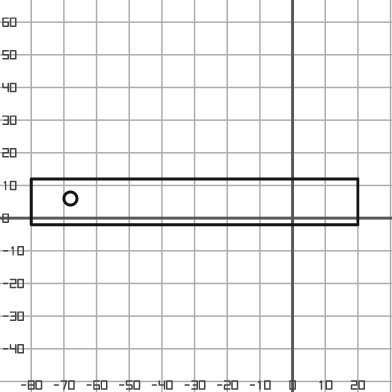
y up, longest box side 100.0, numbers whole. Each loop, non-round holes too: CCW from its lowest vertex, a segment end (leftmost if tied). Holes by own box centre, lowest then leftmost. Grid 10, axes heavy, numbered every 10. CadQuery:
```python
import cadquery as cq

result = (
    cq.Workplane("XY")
    .moveTo(-80.0, -2.0)
    .lineTo(20.0, -2.0)
    .lineTo(20.0, 12.0)
    .lineTo(-80.0, 12.0)
    .close()
    .moveTo(-68.0, 6.0)
    .circle(2.0)
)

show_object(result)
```